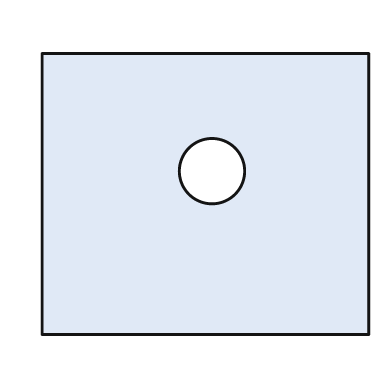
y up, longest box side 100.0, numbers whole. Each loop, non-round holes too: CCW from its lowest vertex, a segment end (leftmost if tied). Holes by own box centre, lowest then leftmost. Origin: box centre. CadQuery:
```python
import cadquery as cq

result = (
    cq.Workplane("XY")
    .moveTo(-50.0, -43.0)
    .lineTo(50.0, -43.0)
    .lineTo(50.0, 43.0)
    .lineTo(-50.0, 43.0)
    .close()
    .moveTo(2.0, 7.0)
    .circle(10.0)
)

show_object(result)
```